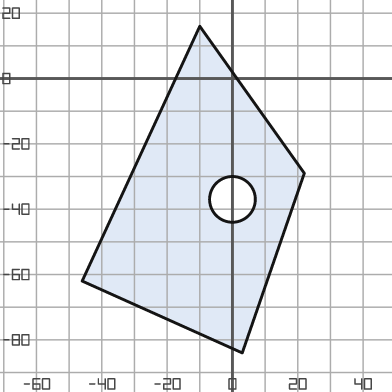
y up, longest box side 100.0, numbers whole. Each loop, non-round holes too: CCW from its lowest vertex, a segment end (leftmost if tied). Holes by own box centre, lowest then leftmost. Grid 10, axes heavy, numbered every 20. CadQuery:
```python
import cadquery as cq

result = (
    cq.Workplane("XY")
    .moveTo(3.0, -84.0)
    .lineTo(22.0, -29.0)
    .lineTo(-10.0, 16.0)
    .lineTo(-46.0, -62.0)
    .close()
    .moveTo(0.0, -37.0)
    .circle(7.0)
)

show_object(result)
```